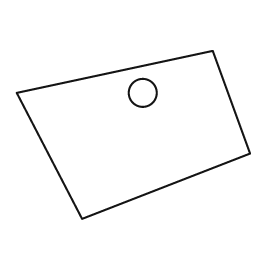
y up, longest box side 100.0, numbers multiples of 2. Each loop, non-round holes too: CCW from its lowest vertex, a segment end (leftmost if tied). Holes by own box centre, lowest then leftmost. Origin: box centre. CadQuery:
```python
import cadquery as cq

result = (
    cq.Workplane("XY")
    .moveTo(-22.0, -36.0)
    .lineTo(50.0, -8.0)
    .lineTo(34.0, 36.0)
    .lineTo(-50.0, 18.0)
    .close()
    .moveTo(4.0, 18.0)
    .circle(6.0)
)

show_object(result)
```